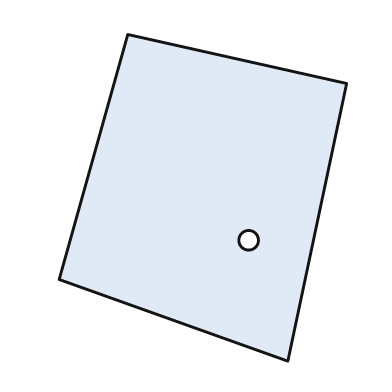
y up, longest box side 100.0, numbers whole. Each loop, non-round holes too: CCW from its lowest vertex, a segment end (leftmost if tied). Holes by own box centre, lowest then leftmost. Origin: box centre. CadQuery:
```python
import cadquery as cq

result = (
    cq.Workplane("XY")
    .moveTo(26.0, -50.0)
    .lineTo(44.0, 35.0)
    .lineTo(-23.0, 50.0)
    .lineTo(-44.0, -25.0)
    .close()
    .moveTo(14.0, -13.0)
    .circle(3.0)
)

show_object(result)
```